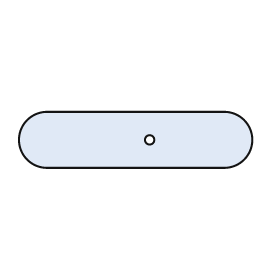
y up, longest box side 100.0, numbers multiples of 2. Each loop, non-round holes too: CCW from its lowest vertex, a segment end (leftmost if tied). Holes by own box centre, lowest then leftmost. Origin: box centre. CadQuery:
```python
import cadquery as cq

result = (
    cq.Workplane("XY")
    .moveTo(-38.0, -12.0)
    .lineTo(38.0, -12.0)
    .threePointArc((50.0, 0.0), (38.0, 12.0))
    .lineTo(-38.0, 12.0)
    .threePointArc((-50.0, 0.0), (-38.0, -12.0))
    .close()
    .moveTo(6.0, 0.0)
    .circle(2.0)
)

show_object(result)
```